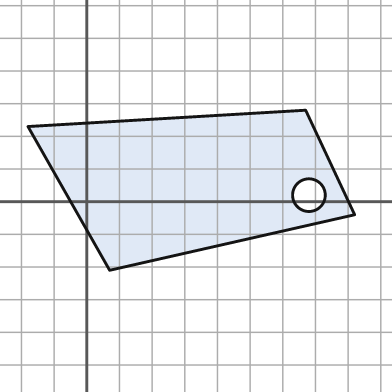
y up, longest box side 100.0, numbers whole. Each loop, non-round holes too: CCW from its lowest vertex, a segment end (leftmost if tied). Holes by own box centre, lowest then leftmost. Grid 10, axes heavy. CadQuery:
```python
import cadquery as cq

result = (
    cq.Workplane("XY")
    .moveTo(7.0, -21.0)
    .lineTo(82.0, -4.0)
    .lineTo(67.0, 28.0)
    .lineTo(-18.0, 23.0)
    .close()
    .moveTo(68.0, 2.0)
    .circle(5.0)
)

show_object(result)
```